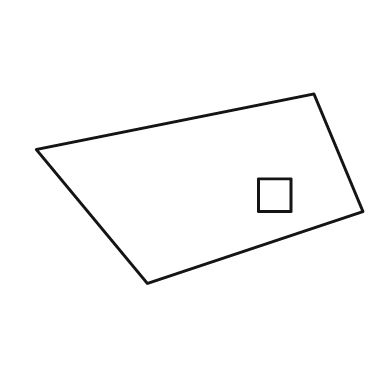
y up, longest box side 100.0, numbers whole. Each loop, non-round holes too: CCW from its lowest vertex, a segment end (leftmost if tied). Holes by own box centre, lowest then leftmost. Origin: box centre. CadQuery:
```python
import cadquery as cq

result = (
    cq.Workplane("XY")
    .moveTo(-16.0, -29.0)
    .lineTo(50.0, -7.0)
    .lineTo(35.0, 29.0)
    .lineTo(-50.0, 12.0)
    .close()
    .moveTo(18.0, -7.0)
    .lineTo(28.0, -7.0)
    .lineTo(28.0, 3.0)
    .lineTo(18.0, 3.0)
    .close()
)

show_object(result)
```